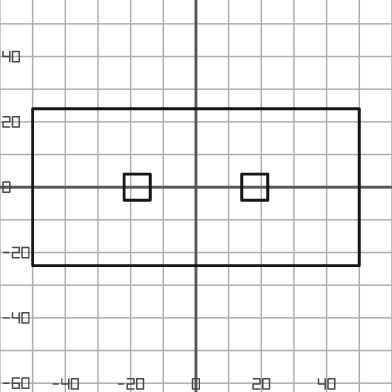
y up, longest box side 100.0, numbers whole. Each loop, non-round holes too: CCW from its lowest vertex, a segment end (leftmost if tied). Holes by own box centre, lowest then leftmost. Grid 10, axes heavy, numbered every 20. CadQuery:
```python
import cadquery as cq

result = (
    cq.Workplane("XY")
    .moveTo(-50.0, -24.0)
    .lineTo(50.0, -24.0)
    .lineTo(50.0, 24.0)
    .lineTo(-50.0, 24.0)
    .close()
    .moveTo(-22.0, -4.0)
    .lineTo(-14.0, -4.0)
    .lineTo(-14.0, 4.0)
    .lineTo(-22.0, 4.0)
    .close()
    .moveTo(14.0, -4.0)
    .lineTo(22.0, -4.0)
    .lineTo(22.0, 4.0)
    .lineTo(14.0, 4.0)
    .close()
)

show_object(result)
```